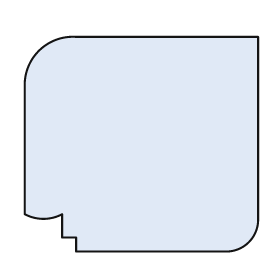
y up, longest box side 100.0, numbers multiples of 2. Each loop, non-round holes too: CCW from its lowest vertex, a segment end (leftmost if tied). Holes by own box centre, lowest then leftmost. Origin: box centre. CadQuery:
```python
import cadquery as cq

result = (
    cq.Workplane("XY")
    .moveTo(-28.0, -46.0)
    .lineTo(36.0, -46.0)
    .threePointArc((46.0, -42.0), (50.0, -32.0))
    .lineTo(50.0, 46.0)
    .lineTo(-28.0, 46.0)
    .threePointArc((-44.0, 40.0), (-50.0, 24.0))
    .lineTo(-50.0, -30.0)
    .threePointArc((-42.0, -32.0), (-34.0, -30.0))
    .lineTo(-34.0, -40.0)
    .lineTo(-28.0, -40.0)
    .close()
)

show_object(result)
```